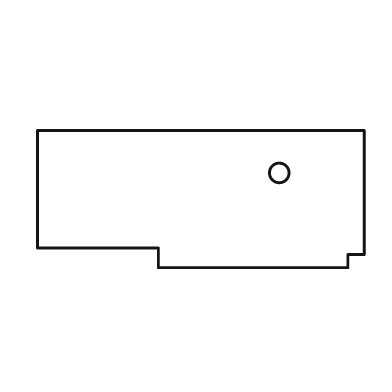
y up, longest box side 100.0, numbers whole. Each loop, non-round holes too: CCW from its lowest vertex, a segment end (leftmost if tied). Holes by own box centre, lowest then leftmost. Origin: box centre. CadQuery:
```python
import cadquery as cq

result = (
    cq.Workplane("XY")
    .moveTo(-13.0, -21.0)
    .lineTo(45.0, -21.0)
    .lineTo(45.0, -17.0)
    .lineTo(50.0, -17.0)
    .lineTo(50.0, 21.0)
    .lineTo(-50.0, 21.0)
    .lineTo(-50.0, -15.0)
    .lineTo(-13.0, -15.0)
    .close()
    .moveTo(24.0, 8.0)
    .circle(3.0)
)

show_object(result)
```